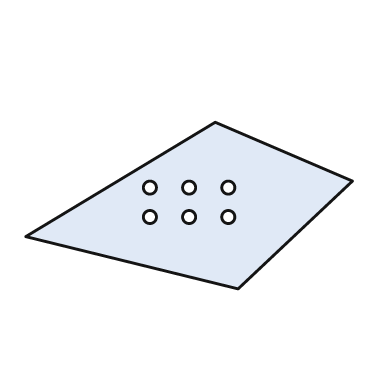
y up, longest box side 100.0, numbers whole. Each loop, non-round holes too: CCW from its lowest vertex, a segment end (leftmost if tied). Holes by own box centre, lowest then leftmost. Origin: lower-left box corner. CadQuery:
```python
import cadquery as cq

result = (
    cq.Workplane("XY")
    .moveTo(65.0, 0.0)
    .lineTo(100.0, 33.0)
    .lineTo(58.0, 51.0)
    .lineTo(0.0, 16.0)
    .close()
    .moveTo(38.0, 22.0)
    .circle(2.0)
    .moveTo(50.0, 22.0)
    .circle(2.0)
    .moveTo(62.0, 22.0)
    .circle(2.0)
    .moveTo(38.0, 31.0)
    .circle(2.0)
    .moveTo(50.0, 31.0)
    .circle(2.0)
    .moveTo(62.0, 31.0)
    .circle(2.0)
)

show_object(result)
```